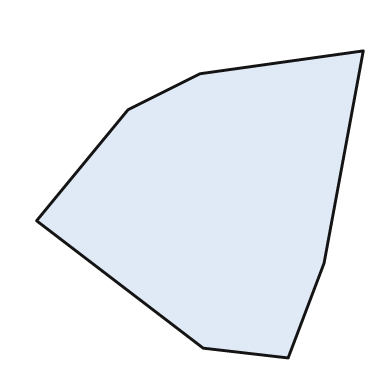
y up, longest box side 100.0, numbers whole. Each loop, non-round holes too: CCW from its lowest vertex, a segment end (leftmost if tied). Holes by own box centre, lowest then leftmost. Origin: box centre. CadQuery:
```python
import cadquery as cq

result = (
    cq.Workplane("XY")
    .moveTo(27.0, -47.0)
    .lineTo(38.0, -18.0)
    .lineTo(50.0, 47.0)
    .lineTo(0.0, 40.0)
    .lineTo(-22.0, 29.0)
    .lineTo(-50.0, -5.0)
    .lineTo(1.0, -44.0)
    .close()
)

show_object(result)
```